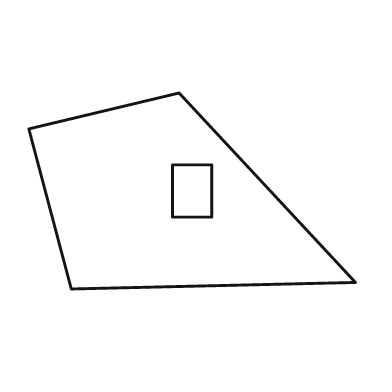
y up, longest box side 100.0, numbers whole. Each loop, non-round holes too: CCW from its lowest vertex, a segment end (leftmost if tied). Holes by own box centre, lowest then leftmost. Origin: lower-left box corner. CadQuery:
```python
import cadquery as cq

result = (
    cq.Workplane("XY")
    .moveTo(13.0, 0.0)
    .lineTo(100.0, 2.0)
    .lineTo(46.0, 60.0)
    .lineTo(0.0, 49.0)
    .close()
    .moveTo(44.0, 22.0)
    .lineTo(56.0, 22.0)
    .lineTo(56.0, 38.0)
    .lineTo(44.0, 38.0)
    .close()
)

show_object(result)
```